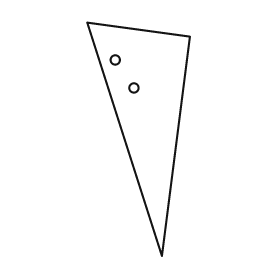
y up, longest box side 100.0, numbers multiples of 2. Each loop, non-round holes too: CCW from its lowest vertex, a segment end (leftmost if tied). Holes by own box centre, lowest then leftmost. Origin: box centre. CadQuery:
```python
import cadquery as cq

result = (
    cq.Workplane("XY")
    .moveTo(10.0, -50.0)
    .lineTo(22.0, 44.0)
    .lineTo(-22.0, 50.0)
    .close()
    .moveTo(-2.0, 22.0)
    .circle(2.0)
    .moveTo(-10.0, 34.0)
    .circle(2.0)
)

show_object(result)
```